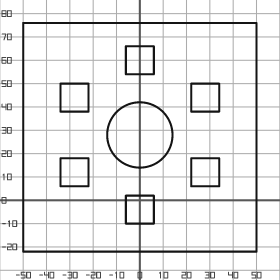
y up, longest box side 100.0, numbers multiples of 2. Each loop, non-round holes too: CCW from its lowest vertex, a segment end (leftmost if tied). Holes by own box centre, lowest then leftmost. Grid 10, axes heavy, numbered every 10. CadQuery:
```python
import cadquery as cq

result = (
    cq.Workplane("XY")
    .moveTo(-50.0, -22.0)
    .lineTo(50.0, -22.0)
    .lineTo(50.0, 76.0)
    .lineTo(-50.0, 76.0)
    .close()
    .moveTo(-6.0, -10.0)
    .lineTo(6.0, -10.0)
    .lineTo(6.0, 2.0)
    .lineTo(-6.0, 2.0)
    .close()
    .moveTo(-34.0, 6.0)
    .lineTo(-22.0, 6.0)
    .lineTo(-22.0, 18.0)
    .lineTo(-34.0, 18.0)
    .close()
    .moveTo(22.0, 6.0)
    .lineTo(34.0, 6.0)
    .lineTo(34.0, 18.0)
    .lineTo(22.0, 18.0)
    .close()
    .moveTo(0.0, 28.0)
    .circle(14.0)
    .moveTo(-34.0, 38.0)
    .lineTo(-22.0, 38.0)
    .lineTo(-22.0, 50.0)
    .lineTo(-34.0, 50.0)
    .close()
    .moveTo(22.0, 38.0)
    .lineTo(34.0, 38.0)
    .lineTo(34.0, 50.0)
    .lineTo(22.0, 50.0)
    .close()
    .moveTo(-6.0, 54.0)
    .lineTo(6.0, 54.0)
    .lineTo(6.0, 66.0)
    .lineTo(-6.0, 66.0)
    .close()
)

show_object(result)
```